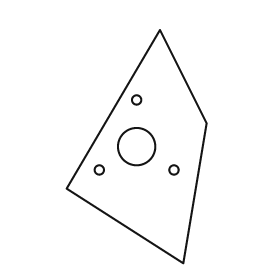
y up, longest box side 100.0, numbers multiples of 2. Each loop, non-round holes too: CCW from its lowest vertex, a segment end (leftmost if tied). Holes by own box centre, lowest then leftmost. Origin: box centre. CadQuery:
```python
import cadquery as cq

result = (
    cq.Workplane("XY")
    .moveTo(20.0, -50.0)
    .lineTo(30.0, 10.0)
    .lineTo(10.0, 50.0)
    .lineTo(-30.0, -18.0)
    .close()
    .moveTo(-16.0, -10.0)
    .circle(2.0)
    .moveTo(16.0, -10.0)
    .circle(2.0)
    .moveTo(0.0, 0.0)
    .circle(8.0)
    .moveTo(0.0, 20.0)
    .circle(2.0)
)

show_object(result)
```